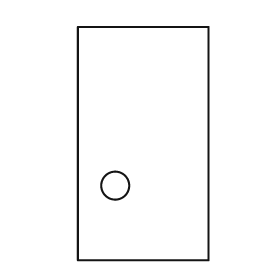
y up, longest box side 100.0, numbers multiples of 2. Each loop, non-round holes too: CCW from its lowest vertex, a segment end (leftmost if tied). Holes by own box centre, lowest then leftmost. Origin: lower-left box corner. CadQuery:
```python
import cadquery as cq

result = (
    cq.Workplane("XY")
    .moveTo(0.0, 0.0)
    .lineTo(56.0, 0.0)
    .lineTo(56.0, 100.0)
    .lineTo(0.0, 100.0)
    .close()
    .moveTo(16.0, 32.0)
    .circle(6.0)
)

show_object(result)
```